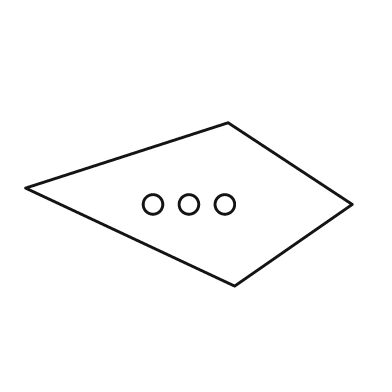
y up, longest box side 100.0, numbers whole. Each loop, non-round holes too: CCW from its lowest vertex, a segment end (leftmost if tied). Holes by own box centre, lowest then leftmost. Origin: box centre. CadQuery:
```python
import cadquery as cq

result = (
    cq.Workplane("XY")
    .moveTo(14.0, -25.0)
    .lineTo(50.0, 0.0)
    .lineTo(12.0, 25.0)
    .lineTo(-50.0, 5.0)
    .close()
    .moveTo(-11.0, 0.0)
    .circle(3.0)
    .moveTo(0.0, 0.0)
    .circle(3.0)
    .moveTo(11.0, 0.0)
    .circle(3.0)
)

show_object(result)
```